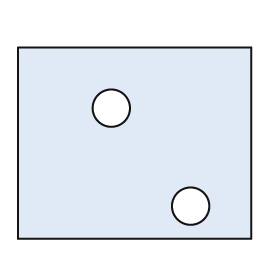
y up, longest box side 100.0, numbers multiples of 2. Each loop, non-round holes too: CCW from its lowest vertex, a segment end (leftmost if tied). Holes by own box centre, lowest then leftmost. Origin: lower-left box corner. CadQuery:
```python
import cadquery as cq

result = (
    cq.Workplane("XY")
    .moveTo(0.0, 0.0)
    .lineTo(100.0, 0.0)
    .lineTo(100.0, 82.0)
    .lineTo(0.0, 82.0)
    .close()
    .moveTo(74.0, 14.0)
    .circle(8.0)
    .moveTo(40.0, 56.0)
    .circle(8.0)
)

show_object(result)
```